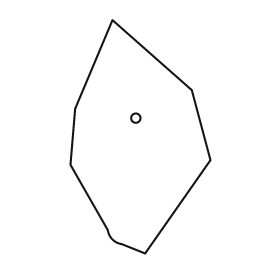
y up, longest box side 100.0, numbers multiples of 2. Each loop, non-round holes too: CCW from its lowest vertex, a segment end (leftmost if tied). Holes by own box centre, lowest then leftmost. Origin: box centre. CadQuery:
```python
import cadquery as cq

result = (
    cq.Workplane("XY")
    .moveTo(2.0, -50.0)
    .lineTo(30.0, -10.0)
    .lineTo(22.0, 20.0)
    .lineTo(-12.0, 50.0)
    .lineTo(-28.0, 12.0)
    .lineTo(-30.0, -12.0)
    .lineTo(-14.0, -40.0)
    .threePointArc((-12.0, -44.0), (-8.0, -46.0))
    .close()
    .moveTo(-2.0, 8.0)
    .circle(2.0)
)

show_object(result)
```